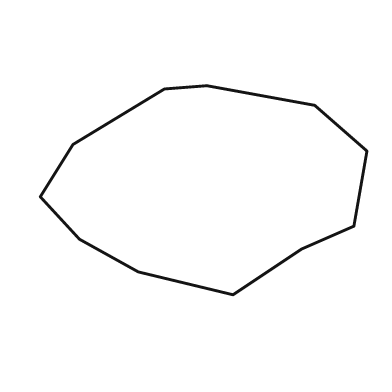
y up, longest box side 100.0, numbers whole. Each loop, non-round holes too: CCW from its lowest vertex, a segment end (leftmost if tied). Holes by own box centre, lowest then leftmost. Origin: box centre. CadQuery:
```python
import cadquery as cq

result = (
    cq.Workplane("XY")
    .moveTo(9.0, -32.0)
    .lineTo(30.0, -18.0)
    .lineTo(46.0, -11.0)
    .lineTo(50.0, 12.0)
    .lineTo(34.0, 26.0)
    .lineTo(1.0, 32.0)
    .lineTo(-12.0, 31.0)
    .lineTo(-40.0, 14.0)
    .lineTo(-50.0, -2.0)
    .lineTo(-38.0, -15.0)
    .lineTo(-20.0, -25.0)
    .close()
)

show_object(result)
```